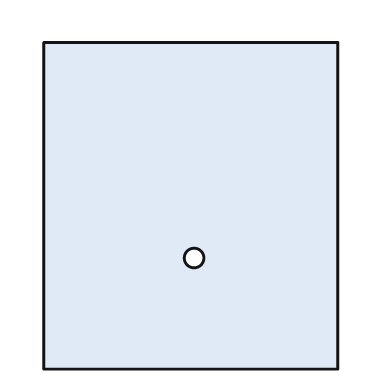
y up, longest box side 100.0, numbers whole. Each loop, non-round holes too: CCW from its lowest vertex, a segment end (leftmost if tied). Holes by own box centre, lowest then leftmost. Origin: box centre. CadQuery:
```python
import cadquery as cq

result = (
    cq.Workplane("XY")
    .moveTo(-45.0, -50.0)
    .lineTo(45.0, -50.0)
    .lineTo(45.0, 50.0)
    .lineTo(-45.0, 50.0)
    .close()
    .moveTo(1.0, -16.0)
    .circle(3.0)
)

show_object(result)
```